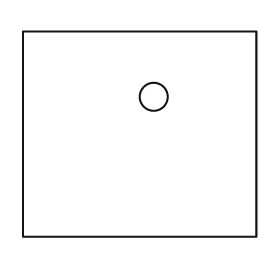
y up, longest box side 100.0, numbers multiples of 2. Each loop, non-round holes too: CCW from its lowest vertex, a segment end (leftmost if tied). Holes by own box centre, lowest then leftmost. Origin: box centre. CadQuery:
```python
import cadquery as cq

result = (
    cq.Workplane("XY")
    .moveTo(-50.0, -44.0)
    .lineTo(50.0, -44.0)
    .lineTo(50.0, 44.0)
    .lineTo(-50.0, 44.0)
    .close()
    .moveTo(6.0, 16.0)
    .circle(6.0)
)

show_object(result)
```